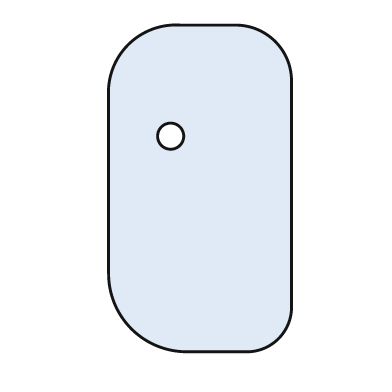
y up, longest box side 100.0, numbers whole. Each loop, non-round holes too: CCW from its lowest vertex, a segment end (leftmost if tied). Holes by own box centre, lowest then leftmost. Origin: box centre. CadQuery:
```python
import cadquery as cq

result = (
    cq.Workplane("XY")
    .moveTo(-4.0, -50.0)
    .lineTo(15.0, -50.0)
    .threePointArc((24.0, -46.0), (28.0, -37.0))
    .lineTo(28.0, 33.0)
    .threePointArc((23.0, 45.0), (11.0, 50.0))
    .lineTo(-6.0, 50.0)
    .threePointArc((-22.0, 44.0), (-28.0, 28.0))
    .lineTo(-28.0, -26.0)
    .threePointArc((-21.0, -43.0), (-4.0, -50.0))
    .close()
    .moveTo(-9.0, 16.0)
    .circle(4.0)
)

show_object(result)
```